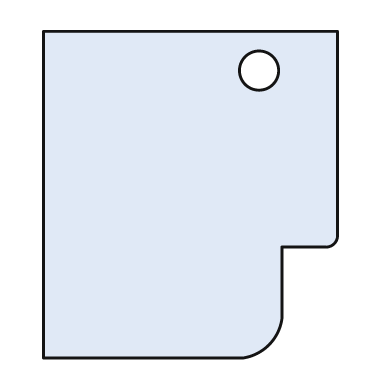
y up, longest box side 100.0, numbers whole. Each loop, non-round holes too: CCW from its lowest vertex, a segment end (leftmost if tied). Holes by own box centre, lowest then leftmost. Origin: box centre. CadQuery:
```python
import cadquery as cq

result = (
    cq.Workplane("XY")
    .moveTo(-45.0, -50.0)
    .lineTo(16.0, -50.0)
    .threePointArc((24.0, -46.0), (28.0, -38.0))
    .lineTo(28.0, -16.0)
    .lineTo(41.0, -16.0)
    .threePointArc((44.0, -15.0), (45.0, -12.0))
    .lineTo(45.0, 50.0)
    .lineTo(-45.0, 50.0)
    .close()
    .moveTo(21.0, 38.0)
    .circle(6.0)
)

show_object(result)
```